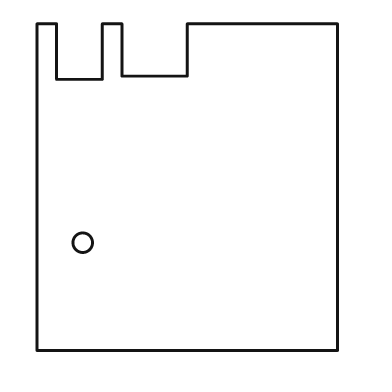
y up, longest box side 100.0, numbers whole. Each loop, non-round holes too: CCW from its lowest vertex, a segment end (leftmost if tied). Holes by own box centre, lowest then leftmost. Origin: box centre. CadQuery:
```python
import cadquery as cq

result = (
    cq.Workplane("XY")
    .moveTo(-46.0, -50.0)
    .lineTo(46.0, -50.0)
    .lineTo(46.0, 50.0)
    .lineTo(0.0, 50.0)
    .lineTo(0.0, 34.0)
    .lineTo(-20.0, 34.0)
    .lineTo(-20.0, 50.0)
    .lineTo(-26.0, 50.0)
    .lineTo(-26.0, 33.0)
    .lineTo(-40.0, 33.0)
    .lineTo(-40.0, 50.0)
    .lineTo(-46.0, 50.0)
    .close()
    .moveTo(-32.0, -17.0)
    .circle(3.0)
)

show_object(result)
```